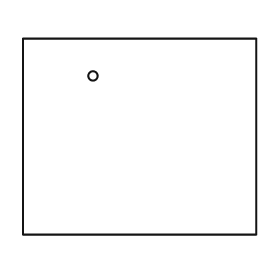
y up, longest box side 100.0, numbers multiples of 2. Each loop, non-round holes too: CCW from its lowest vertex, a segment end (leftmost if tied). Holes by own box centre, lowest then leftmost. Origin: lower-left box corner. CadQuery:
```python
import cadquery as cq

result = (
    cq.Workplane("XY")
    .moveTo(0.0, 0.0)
    .lineTo(100.0, 0.0)
    .lineTo(100.0, 84.0)
    .lineTo(0.0, 84.0)
    .close()
    .moveTo(30.0, 68.0)
    .circle(2.0)
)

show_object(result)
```